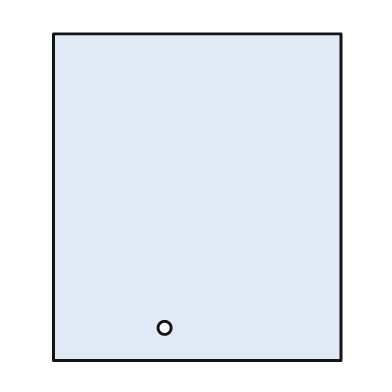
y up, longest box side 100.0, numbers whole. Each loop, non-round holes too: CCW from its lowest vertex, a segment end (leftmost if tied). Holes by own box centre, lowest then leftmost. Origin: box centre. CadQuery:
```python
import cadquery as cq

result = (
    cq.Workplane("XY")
    .moveTo(-44.0, -50.0)
    .lineTo(44.0, -50.0)
    .lineTo(44.0, 50.0)
    .lineTo(-44.0, 50.0)
    .close()
    .moveTo(-10.0, -40.0)
    .circle(2.0)
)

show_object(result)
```